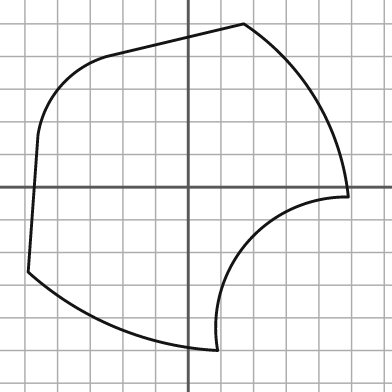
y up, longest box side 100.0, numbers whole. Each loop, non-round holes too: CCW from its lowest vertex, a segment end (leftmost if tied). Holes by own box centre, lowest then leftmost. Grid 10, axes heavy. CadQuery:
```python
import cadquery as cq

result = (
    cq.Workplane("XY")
    .moveTo(9.0, -50.0)
    .threePointArc((18.0, -17.0), (49.0, -3.0))
    .threePointArc((39.0, 27.0), (17.0, 50.0))
    .lineTo(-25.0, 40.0)
    .threePointArc((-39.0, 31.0), (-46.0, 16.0))
    .lineTo(-49.0, -26.0)
    .threePointArc((-22.0, -43.0), (9.0, -50.0))
    .close()
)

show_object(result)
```